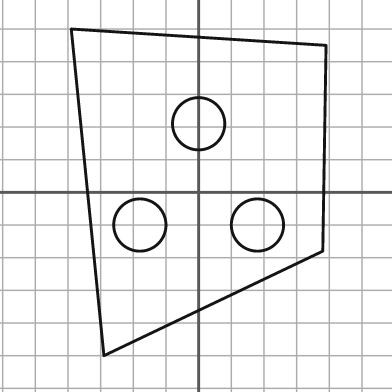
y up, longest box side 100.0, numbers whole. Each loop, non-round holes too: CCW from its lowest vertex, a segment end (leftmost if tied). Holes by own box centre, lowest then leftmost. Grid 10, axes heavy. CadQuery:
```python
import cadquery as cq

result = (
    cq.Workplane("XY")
    .moveTo(-29.0, -50.0)
    .lineTo(38.0, -18.0)
    .lineTo(39.0, 45.0)
    .lineTo(-39.0, 50.0)
    .close()
    .moveTo(-18.0, -10.0)
    .circle(8.0)
    .moveTo(18.0, -10.0)
    .circle(8.0)
    .moveTo(0.0, 21.0)
    .circle(8.0)
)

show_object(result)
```